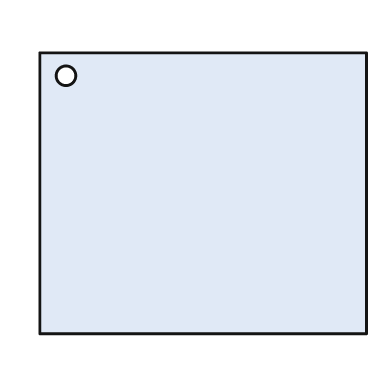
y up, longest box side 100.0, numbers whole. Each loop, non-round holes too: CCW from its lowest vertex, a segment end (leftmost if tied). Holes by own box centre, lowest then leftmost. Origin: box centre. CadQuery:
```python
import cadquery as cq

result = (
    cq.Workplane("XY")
    .moveTo(-50.0, -43.0)
    .lineTo(50.0, -43.0)
    .lineTo(50.0, 43.0)
    .lineTo(-50.0, 43.0)
    .close()
    .moveTo(-42.0, 36.0)
    .circle(3.0)
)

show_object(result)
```